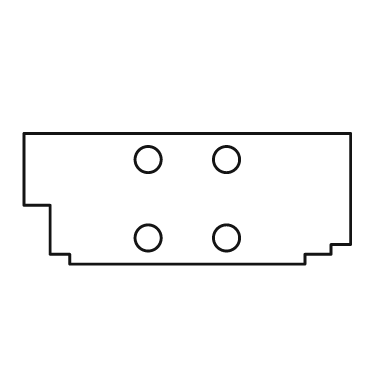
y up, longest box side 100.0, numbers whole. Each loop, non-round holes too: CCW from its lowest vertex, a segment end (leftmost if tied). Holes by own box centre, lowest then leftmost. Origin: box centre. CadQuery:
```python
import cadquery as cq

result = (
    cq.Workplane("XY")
    .moveTo(-36.0, -20.0)
    .lineTo(36.0, -20.0)
    .lineTo(36.0, -17.0)
    .lineTo(44.0, -17.0)
    .lineTo(44.0, -14.0)
    .lineTo(50.0, -14.0)
    .lineTo(50.0, 20.0)
    .lineTo(-50.0, 20.0)
    .lineTo(-50.0, -2.0)
    .lineTo(-42.0, -2.0)
    .lineTo(-42.0, -17.0)
    .lineTo(-36.0, -17.0)
    .close()
    .moveTo(-12.0, -12.0)
    .circle(4.0)
    .moveTo(12.0, -12.0)
    .circle(4.0)
    .moveTo(-12.0, 12.0)
    .circle(4.0)
    .moveTo(12.0, 12.0)
    .circle(4.0)
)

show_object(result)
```